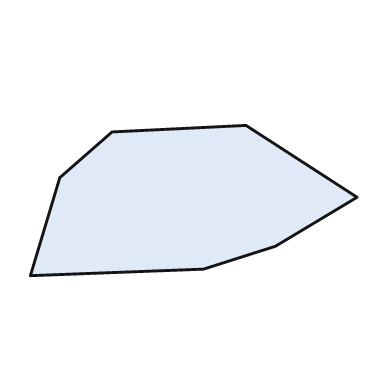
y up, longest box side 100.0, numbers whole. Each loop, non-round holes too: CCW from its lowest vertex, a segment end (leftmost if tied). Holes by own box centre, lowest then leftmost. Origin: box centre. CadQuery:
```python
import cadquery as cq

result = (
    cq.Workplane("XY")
    .moveTo(-50.0, -23.0)
    .lineTo(3.0, -21.0)
    .lineTo(25.0, -14.0)
    .lineTo(50.0, 1.0)
    .lineTo(16.0, 23.0)
    .lineTo(-25.0, 21.0)
    .lineTo(-41.0, 7.0)
    .close()
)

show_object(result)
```